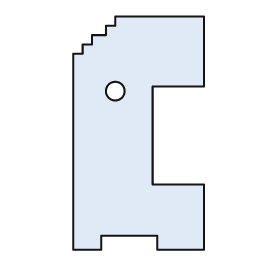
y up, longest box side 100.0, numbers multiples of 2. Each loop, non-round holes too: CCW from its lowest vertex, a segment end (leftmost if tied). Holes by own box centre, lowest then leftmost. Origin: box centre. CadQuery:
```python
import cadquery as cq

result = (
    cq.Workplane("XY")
    .moveTo(-28.0, -50.0)
    .lineTo(-16.0, -50.0)
    .lineTo(-16.0, -44.0)
    .lineTo(8.0, -44.0)
    .lineTo(8.0, -50.0)
    .lineTo(28.0, -50.0)
    .lineTo(28.0, -22.0)
    .lineTo(6.0, -22.0)
    .lineTo(6.0, 20.0)
    .lineTo(28.0, 20.0)
    .lineTo(28.0, 50.0)
    .lineTo(-10.0, 50.0)
    .lineTo(-10.0, 46.0)
    .lineTo(-14.0, 46.0)
    .lineTo(-14.0, 42.0)
    .lineTo(-20.0, 42.0)
    .lineTo(-20.0, 38.0)
    .lineTo(-24.0, 38.0)
    .lineTo(-24.0, 34.0)
    .lineTo(-28.0, 34.0)
    .close()
    .moveTo(-10.0, 18.0)
    .circle(4.0)
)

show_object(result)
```